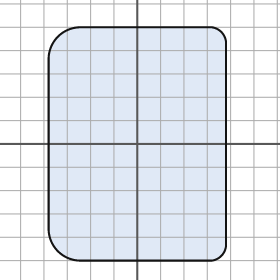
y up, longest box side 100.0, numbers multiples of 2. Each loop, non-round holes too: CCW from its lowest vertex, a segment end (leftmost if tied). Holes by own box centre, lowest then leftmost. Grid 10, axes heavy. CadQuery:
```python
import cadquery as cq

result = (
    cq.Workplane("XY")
    .moveTo(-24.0, -50.0)
    .lineTo(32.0, -50.0)
    .threePointArc((36.0, -48.0), (38.0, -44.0))
    .lineTo(38.0, 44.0)
    .threePointArc((36.0, 48.0), (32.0, 50.0))
    .lineTo(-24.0, 50.0)
    .threePointArc((-34.0, 46.0), (-38.0, 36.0))
    .lineTo(-38.0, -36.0)
    .threePointArc((-34.0, -46.0), (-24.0, -50.0))
    .close()
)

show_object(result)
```